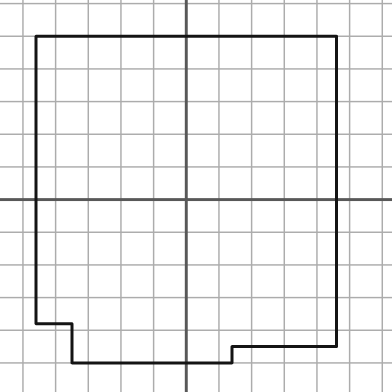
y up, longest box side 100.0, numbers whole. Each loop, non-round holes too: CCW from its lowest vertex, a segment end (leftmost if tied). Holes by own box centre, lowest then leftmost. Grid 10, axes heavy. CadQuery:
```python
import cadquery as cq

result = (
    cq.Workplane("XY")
    .moveTo(-35.0, -50.0)
    .lineTo(14.0, -50.0)
    .lineTo(14.0, -45.0)
    .lineTo(46.0, -45.0)
    .lineTo(46.0, 50.0)
    .lineTo(-46.0, 50.0)
    .lineTo(-46.0, -38.0)
    .lineTo(-35.0, -38.0)
    .close()
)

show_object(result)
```